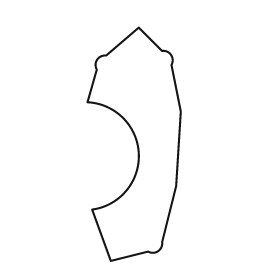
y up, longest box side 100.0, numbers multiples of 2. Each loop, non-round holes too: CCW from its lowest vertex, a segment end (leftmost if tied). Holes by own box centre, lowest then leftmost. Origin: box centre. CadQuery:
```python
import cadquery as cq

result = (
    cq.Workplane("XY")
    .moveTo(-10.0, -50.0)
    .lineTo(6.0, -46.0)
    .threePointArc((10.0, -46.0), (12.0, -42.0))
    .lineTo(18.0, -18.0)
    .lineTo(20.0, 14.0)
    .lineTo(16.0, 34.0)
    .threePointArc((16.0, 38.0), (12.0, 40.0))
    .lineTo(2.0, 50.0)
    .lineTo(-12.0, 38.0)
    .threePointArc((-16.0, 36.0), (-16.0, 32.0))
    .lineTo(-20.0, 18.0)
    .threePointArc((2.0, -4.0), (-18.0, -28.0))
    .close()
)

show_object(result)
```